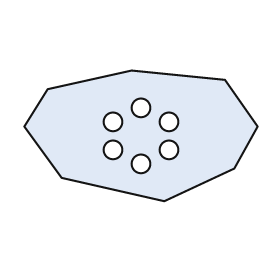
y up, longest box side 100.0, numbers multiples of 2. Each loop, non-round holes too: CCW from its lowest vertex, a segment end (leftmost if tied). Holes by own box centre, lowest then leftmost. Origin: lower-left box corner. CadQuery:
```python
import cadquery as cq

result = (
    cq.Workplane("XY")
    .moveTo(60.0, 0.0)
    .lineTo(90.0, 14.0)
    .lineTo(100.0, 32.0)
    .lineTo(86.0, 52.0)
    .lineTo(46.0, 56.0)
    .lineTo(10.0, 48.0)
    .lineTo(0.0, 32.0)
    .lineTo(16.0, 10.0)
    .close()
    .moveTo(50.0, 16.0)
    .circle(4.0)
    .moveTo(38.0, 22.0)
    .circle(4.0)
    .moveTo(62.0, 22.0)
    .circle(4.0)
    .moveTo(38.0, 34.0)
    .circle(4.0)
    .moveTo(62.0, 34.0)
    .circle(4.0)
    .moveTo(50.0, 40.0)
    .circle(4.0)
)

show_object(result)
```